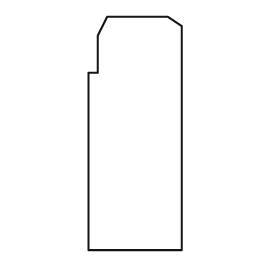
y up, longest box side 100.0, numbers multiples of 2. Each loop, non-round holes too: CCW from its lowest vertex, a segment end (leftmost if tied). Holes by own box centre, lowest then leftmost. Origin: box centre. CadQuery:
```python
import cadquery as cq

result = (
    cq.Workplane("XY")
    .moveTo(-20.0, -50.0)
    .lineTo(20.0, -50.0)
    .lineTo(20.0, 46.0)
    .lineTo(14.0, 50.0)
    .lineTo(-12.0, 50.0)
    .lineTo(-16.0, 42.0)
    .lineTo(-16.0, 26.0)
    .lineTo(-20.0, 26.0)
    .close()
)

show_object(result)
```